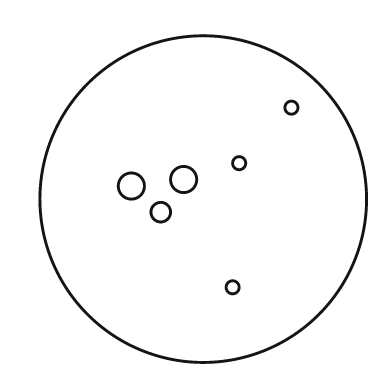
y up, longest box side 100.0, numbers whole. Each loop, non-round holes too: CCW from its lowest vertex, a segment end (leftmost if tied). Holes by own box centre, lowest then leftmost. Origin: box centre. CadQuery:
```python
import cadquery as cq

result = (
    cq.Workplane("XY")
    .moveTo(0.0, 0.0)
    .circle(50.0)
    .moveTo(9.0, -27.0)
    .circle(2.0)
    .moveTo(-13.0, -4.0)
    .circle(3.0)
    .moveTo(-22.0, 4.0)
    .circle(4.0)
    .moveTo(-6.0, 6.0)
    .circle(4.0)
    .moveTo(11.0, 11.0)
    .circle(2.0)
    .moveTo(27.0, 28.0)
    .circle(2.0)
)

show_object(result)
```